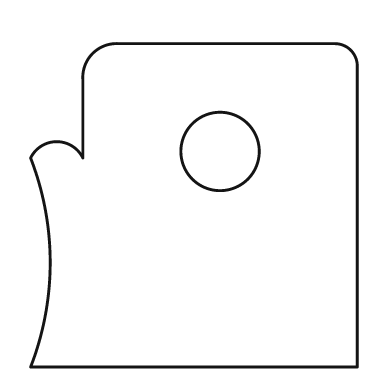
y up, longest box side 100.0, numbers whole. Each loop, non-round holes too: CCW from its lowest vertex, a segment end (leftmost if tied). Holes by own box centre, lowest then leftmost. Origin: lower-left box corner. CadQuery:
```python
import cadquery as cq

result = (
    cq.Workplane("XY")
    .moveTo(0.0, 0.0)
    .lineTo(100.0, 0.0)
    .lineTo(100.0, 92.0)
    .threePointArc((98.0, 97.0), (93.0, 99.0))
    .lineTo(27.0, 99.0)
    .threePointArc((19.0, 96.0), (16.0, 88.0))
    .lineTo(16.0, 64.0)
    .threePointArc((8.0, 69.0), (0.0, 64.0))
    .threePointArc((6.0, 32.0), (0.0, 0.0))
    .close()
    .moveTo(58.0, 66.0)
    .circle(12.0)
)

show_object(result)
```